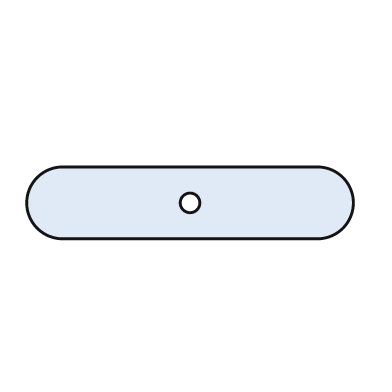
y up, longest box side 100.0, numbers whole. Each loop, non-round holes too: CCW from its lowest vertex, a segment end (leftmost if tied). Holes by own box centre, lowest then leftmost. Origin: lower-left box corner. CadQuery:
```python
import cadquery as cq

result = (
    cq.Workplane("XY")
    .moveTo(11.0, 0.0)
    .lineTo(89.0, 0.0)
    .threePointArc((100.0, 11.0), (89.0, 22.0))
    .lineTo(11.0, 22.0)
    .threePointArc((0.0, 11.0), (11.0, 0.0))
    .close()
    .moveTo(50.0, 11.0)
    .circle(3.0)
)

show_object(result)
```